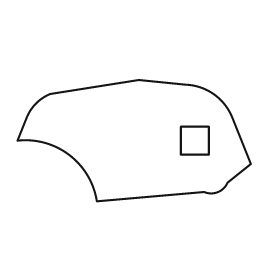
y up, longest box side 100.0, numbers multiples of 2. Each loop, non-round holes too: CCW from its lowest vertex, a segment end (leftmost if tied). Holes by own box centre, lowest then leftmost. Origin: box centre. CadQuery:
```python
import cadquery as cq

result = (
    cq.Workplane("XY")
    .moveTo(-16.0, -26.0)
    .lineTo(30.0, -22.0)
    .threePointArc((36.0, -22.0), (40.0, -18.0))
    .lineTo(50.0, -10.0)
    .lineTo(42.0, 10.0)
    .threePointArc((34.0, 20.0), (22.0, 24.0))
    .lineTo(2.0, 26.0)
    .lineTo(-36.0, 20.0)
    .threePointArc((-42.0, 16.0), (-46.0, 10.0))
    .lineTo(-50.0, 0.0)
    .threePointArc((-28.0, -6.0), (-16.0, -26.0))
    .close()
    .moveTo(20.0, -6.0)
    .lineTo(32.0, -6.0)
    .lineTo(32.0, 6.0)
    .lineTo(20.0, 6.0)
    .close()
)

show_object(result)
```